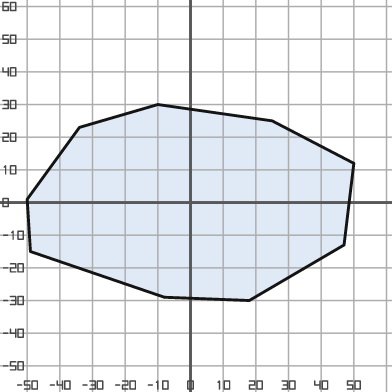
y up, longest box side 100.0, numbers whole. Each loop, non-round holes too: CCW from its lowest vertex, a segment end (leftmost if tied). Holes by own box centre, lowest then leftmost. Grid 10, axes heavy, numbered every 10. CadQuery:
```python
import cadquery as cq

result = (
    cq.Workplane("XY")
    .moveTo(18.0, -30.0)
    .lineTo(47.0, -13.0)
    .lineTo(50.0, 12.0)
    .lineTo(25.0, 25.0)
    .lineTo(-10.0, 30.0)
    .lineTo(-34.0, 23.0)
    .lineTo(-50.0, 1.0)
    .lineTo(-49.0, -15.0)
    .lineTo(-8.0, -29.0)
    .close()
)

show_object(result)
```